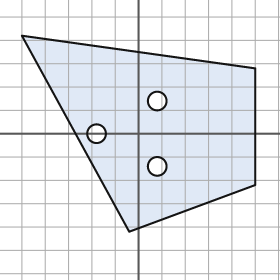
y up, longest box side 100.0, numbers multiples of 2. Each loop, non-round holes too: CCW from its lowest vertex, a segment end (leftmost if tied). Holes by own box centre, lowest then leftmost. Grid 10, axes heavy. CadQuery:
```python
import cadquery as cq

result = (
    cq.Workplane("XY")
    .moveTo(-4.0, -42.0)
    .lineTo(50.0, -22.0)
    .lineTo(50.0, 28.0)
    .lineTo(-50.0, 42.0)
    .close()
    .moveTo(8.0, -14.0)
    .circle(4.0)
    .moveTo(-18.0, 0.0)
    .circle(4.0)
    .moveTo(8.0, 14.0)
    .circle(4.0)
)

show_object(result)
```